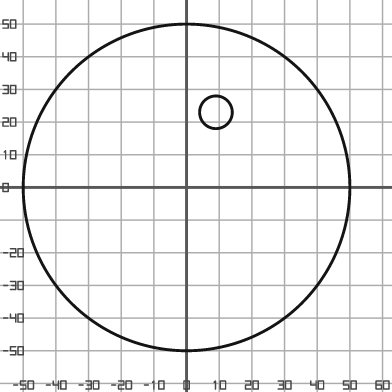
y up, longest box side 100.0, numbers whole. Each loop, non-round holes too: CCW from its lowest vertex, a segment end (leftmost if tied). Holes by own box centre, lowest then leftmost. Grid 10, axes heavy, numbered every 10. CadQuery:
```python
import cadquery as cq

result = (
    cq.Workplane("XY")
    .moveTo(0.0, 0.0)
    .circle(50.0)
    .moveTo(9.0, 23.0)
    .circle(5.0)
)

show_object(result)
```